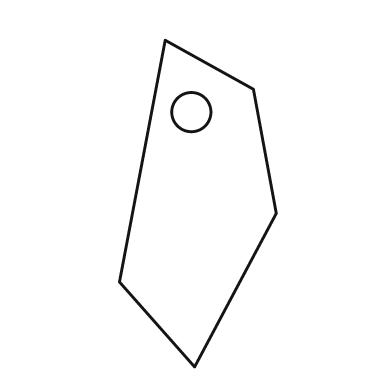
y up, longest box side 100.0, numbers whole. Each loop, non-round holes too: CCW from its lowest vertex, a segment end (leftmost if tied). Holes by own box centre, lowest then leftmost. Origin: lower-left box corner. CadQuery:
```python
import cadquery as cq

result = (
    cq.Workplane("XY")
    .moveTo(23.0, 0.0)
    .lineTo(48.0, 47.0)
    .lineTo(41.0, 85.0)
    .lineTo(14.0, 100.0)
    .lineTo(0.0, 26.0)
    .close()
    .moveTo(22.0, 78.0)
    .circle(6.0)
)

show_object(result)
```